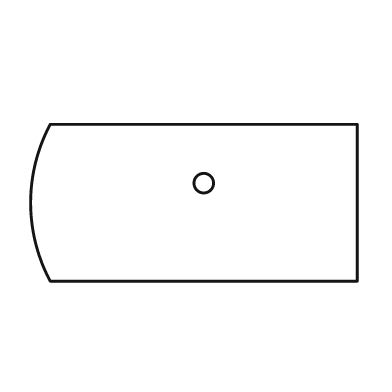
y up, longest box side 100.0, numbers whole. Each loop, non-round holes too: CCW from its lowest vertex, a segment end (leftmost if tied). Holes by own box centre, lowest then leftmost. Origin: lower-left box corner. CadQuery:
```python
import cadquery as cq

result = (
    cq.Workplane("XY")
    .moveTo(6.0, 0.0)
    .lineTo(100.0, 0.0)
    .lineTo(100.0, 48.0)
    .lineTo(6.0, 48.0)
    .threePointArc((0.0, 24.0), (6.0, 0.0))
    .close()
    .moveTo(53.0, 30.0)
    .circle(3.0)
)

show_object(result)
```